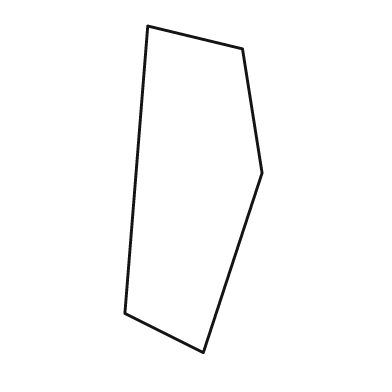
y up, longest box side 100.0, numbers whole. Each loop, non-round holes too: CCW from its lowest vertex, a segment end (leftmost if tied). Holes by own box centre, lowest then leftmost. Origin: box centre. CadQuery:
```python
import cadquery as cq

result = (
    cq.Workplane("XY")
    .moveTo(3.0, -50.0)
    .lineTo(21.0, 5.0)
    .lineTo(15.0, 43.0)
    .lineTo(-14.0, 50.0)
    .lineTo(-21.0, -38.0)
    .close()
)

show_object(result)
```